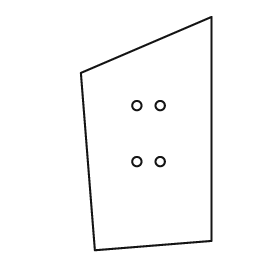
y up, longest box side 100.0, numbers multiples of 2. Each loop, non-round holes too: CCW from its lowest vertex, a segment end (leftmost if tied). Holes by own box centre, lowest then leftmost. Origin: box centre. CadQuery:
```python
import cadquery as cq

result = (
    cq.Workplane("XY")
    .moveTo(-22.0, -50.0)
    .lineTo(28.0, -46.0)
    .lineTo(28.0, 50.0)
    .lineTo(-28.0, 26.0)
    .close()
    .moveTo(-4.0, -12.0)
    .circle(2.0)
    .moveTo(6.0, -12.0)
    .circle(2.0)
    .moveTo(-4.0, 12.0)
    .circle(2.0)
    .moveTo(6.0, 12.0)
    .circle(2.0)
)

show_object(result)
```